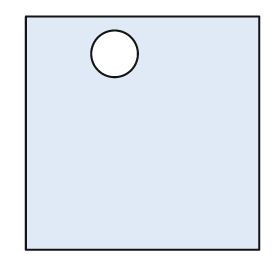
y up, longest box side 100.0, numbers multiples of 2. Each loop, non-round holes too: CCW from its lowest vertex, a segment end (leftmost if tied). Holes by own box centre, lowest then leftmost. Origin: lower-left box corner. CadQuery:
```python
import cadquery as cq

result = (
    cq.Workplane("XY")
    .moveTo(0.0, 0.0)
    .lineTo(100.0, 0.0)
    .lineTo(100.0, 100.0)
    .lineTo(0.0, 100.0)
    .close()
    .moveTo(38.0, 84.0)
    .circle(10.0)
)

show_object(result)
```